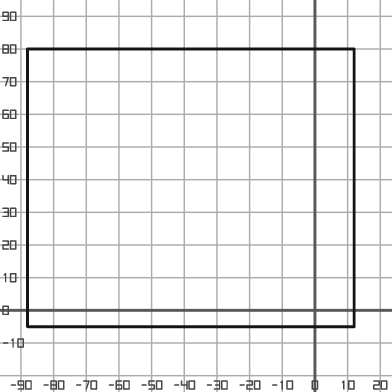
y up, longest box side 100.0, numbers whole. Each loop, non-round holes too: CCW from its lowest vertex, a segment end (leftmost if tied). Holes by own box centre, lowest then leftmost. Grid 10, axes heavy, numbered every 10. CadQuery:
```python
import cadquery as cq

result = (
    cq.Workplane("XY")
    .moveTo(-88.0, -5.0)
    .lineTo(12.0, -5.0)
    .lineTo(12.0, 80.0)
    .lineTo(-88.0, 80.0)
    .close()
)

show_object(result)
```